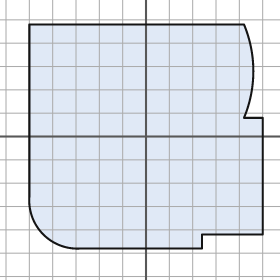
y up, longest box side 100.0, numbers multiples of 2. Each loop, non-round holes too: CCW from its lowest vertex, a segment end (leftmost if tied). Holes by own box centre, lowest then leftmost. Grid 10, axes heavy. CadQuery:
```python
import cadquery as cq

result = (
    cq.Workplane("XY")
    .moveTo(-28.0, -48.0)
    .lineTo(24.0, -48.0)
    .lineTo(24.0, -42.0)
    .lineTo(50.0, -42.0)
    .lineTo(50.0, 8.0)
    .lineTo(42.0, 8.0)
    .threePointArc((46.0, 28.0), (42.0, 48.0))
    .lineTo(-50.0, 48.0)
    .lineTo(-50.0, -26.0)
    .threePointArc((-44.0, -42.0), (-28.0, -48.0))
    .close()
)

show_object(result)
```